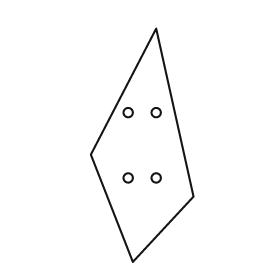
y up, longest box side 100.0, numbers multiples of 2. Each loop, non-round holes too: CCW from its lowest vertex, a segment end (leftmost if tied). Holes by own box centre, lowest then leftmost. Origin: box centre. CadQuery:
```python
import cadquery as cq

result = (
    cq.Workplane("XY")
    .moveTo(-4.0, -50.0)
    .lineTo(22.0, -22.0)
    .lineTo(6.0, 50.0)
    .lineTo(-22.0, -4.0)
    .close()
    .moveTo(-6.0, -14.0)
    .circle(2.0)
    .moveTo(6.0, -14.0)
    .circle(2.0)
    .moveTo(-6.0, 14.0)
    .circle(2.0)
    .moveTo(6.0, 14.0)
    .circle(2.0)
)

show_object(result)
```